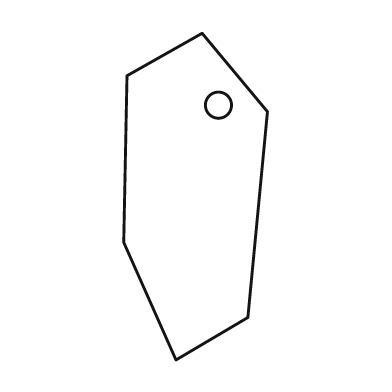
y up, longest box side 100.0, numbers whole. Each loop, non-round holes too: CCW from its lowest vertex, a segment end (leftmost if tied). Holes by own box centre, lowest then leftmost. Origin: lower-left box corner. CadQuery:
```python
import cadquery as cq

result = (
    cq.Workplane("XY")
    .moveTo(16.0, 0.0)
    .lineTo(38.0, 13.0)
    .lineTo(44.0, 76.0)
    .lineTo(24.0, 100.0)
    .lineTo(1.0, 87.0)
    .lineTo(0.0, 36.0)
    .close()
    .moveTo(29.0, 78.0)
    .circle(4.0)
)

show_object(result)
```